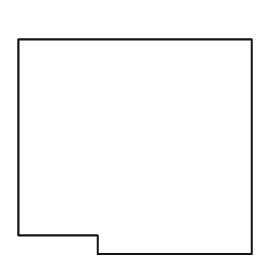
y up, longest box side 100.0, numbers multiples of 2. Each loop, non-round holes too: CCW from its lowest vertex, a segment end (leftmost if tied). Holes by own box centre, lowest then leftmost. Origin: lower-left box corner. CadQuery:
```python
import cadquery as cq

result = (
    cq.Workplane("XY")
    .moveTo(34.0, 0.0)
    .lineTo(100.0, 0.0)
    .lineTo(100.0, 92.0)
    .lineTo(0.0, 92.0)
    .lineTo(0.0, 8.0)
    .lineTo(34.0, 8.0)
    .close()
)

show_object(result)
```